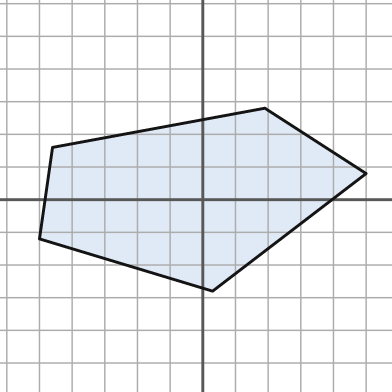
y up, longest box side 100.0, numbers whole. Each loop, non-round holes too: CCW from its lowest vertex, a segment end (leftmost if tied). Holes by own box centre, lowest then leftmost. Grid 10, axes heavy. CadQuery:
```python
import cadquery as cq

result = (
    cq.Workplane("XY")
    .moveTo(3.0, -28.0)
    .lineTo(50.0, 8.0)
    .lineTo(19.0, 28.0)
    .lineTo(-46.0, 16.0)
    .lineTo(-50.0, -12.0)
    .close()
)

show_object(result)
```